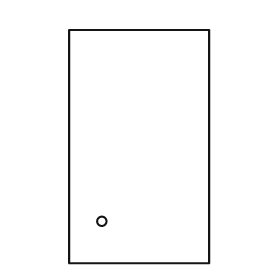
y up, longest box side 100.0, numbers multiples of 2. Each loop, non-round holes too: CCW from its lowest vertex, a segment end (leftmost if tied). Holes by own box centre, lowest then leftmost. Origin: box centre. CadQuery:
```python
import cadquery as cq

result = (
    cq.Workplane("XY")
    .moveTo(-30.0, -50.0)
    .lineTo(30.0, -50.0)
    .lineTo(30.0, 50.0)
    .lineTo(-30.0, 50.0)
    .close()
    .moveTo(-16.0, -32.0)
    .circle(2.0)
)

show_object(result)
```